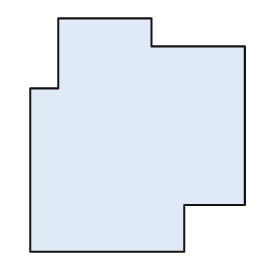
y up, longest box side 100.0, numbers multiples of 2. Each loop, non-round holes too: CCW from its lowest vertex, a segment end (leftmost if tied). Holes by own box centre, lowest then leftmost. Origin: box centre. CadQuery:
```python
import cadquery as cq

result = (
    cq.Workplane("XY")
    .moveTo(-46.0, -50.0)
    .lineTo(20.0, -50.0)
    .lineTo(20.0, -30.0)
    .lineTo(46.0, -30.0)
    .lineTo(46.0, 38.0)
    .lineTo(6.0, 38.0)
    .lineTo(6.0, 50.0)
    .lineTo(-34.0, 50.0)
    .lineTo(-34.0, 20.0)
    .lineTo(-46.0, 20.0)
    .close()
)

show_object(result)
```